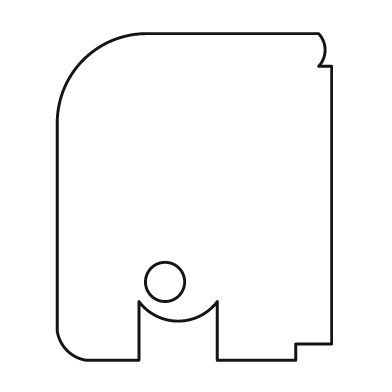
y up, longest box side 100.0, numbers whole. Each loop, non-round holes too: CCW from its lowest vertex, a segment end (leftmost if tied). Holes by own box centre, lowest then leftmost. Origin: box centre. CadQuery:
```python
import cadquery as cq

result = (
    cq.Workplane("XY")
    .moveTo(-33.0, -50.0)
    .lineTo(-17.0, -50.0)
    .lineTo(-17.0, -32.0)
    .threePointArc((-5.0, -38.0), (7.0, -32.0))
    .lineTo(7.0, -50.0)
    .lineTo(31.0, -50.0)
    .lineTo(31.0, -45.0)
    .lineTo(42.0, -45.0)
    .lineTo(42.0, 40.0)
    .lineTo(38.0, 40.0)
    .threePointArc((40.0, 45.0), (38.0, 50.0))
    .lineTo(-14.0, 50.0)
    .threePointArc((-34.0, 42.0), (-42.0, 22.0))
    .lineTo(-42.0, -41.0)
    .threePointArc((-39.0, -47.0), (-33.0, -50.0))
    .close()
    .moveTo(-9.0, -26.0)
    .circle(6.0)
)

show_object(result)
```